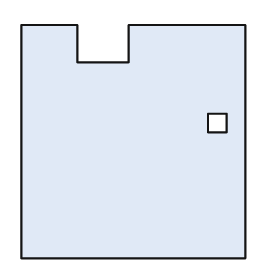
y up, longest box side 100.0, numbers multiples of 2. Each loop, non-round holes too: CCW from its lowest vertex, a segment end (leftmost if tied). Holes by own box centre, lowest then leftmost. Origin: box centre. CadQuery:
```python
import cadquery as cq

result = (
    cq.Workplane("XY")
    .moveTo(-48.0, -50.0)
    .lineTo(48.0, -50.0)
    .lineTo(48.0, 50.0)
    .lineTo(-2.0, 50.0)
    .lineTo(-2.0, 34.0)
    .lineTo(-24.0, 34.0)
    .lineTo(-24.0, 50.0)
    .lineTo(-48.0, 50.0)
    .close()
    .moveTo(32.0, 4.0)
    .lineTo(40.0, 4.0)
    .lineTo(40.0, 12.0)
    .lineTo(32.0, 12.0)
    .close()
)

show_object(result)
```